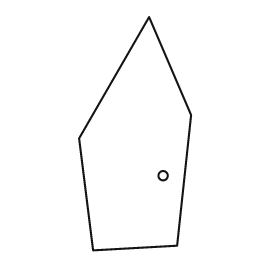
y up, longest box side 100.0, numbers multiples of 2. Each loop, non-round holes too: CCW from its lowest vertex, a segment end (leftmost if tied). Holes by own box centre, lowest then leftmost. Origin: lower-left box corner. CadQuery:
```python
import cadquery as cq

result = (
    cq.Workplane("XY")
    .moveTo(6.0, 0.0)
    .lineTo(42.0, 2.0)
    .lineTo(48.0, 58.0)
    .lineTo(30.0, 100.0)
    .lineTo(0.0, 48.0)
    .close()
    .moveTo(36.0, 32.0)
    .circle(2.0)
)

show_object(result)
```